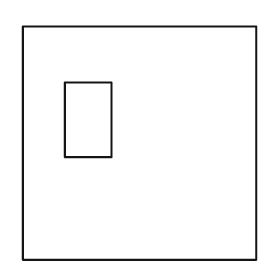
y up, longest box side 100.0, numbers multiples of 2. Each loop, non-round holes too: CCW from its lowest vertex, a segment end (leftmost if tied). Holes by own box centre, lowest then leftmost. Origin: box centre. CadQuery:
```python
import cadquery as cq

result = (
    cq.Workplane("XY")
    .moveTo(-50.0, -50.0)
    .lineTo(50.0, -50.0)
    .lineTo(50.0, 50.0)
    .lineTo(-50.0, 50.0)
    .close()
    .moveTo(-32.0, -6.0)
    .lineTo(-12.0, -6.0)
    .lineTo(-12.0, 26.0)
    .lineTo(-32.0, 26.0)
    .close()
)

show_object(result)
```